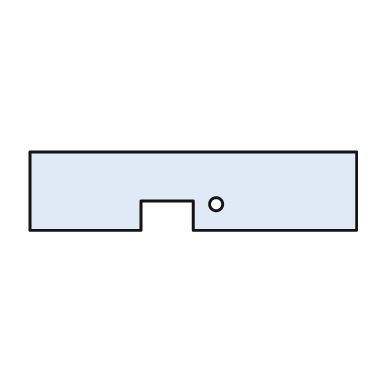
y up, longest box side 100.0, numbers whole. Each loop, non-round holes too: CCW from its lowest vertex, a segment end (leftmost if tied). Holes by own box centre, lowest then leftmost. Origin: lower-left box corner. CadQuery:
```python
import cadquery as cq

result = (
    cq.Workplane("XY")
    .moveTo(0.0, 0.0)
    .lineTo(34.0, 0.0)
    .lineTo(34.0, 9.0)
    .lineTo(50.0, 9.0)
    .lineTo(50.0, 0.0)
    .lineTo(100.0, 0.0)
    .lineTo(100.0, 24.0)
    .lineTo(0.0, 24.0)
    .close()
    .moveTo(57.0, 8.0)
    .circle(2.0)
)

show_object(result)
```